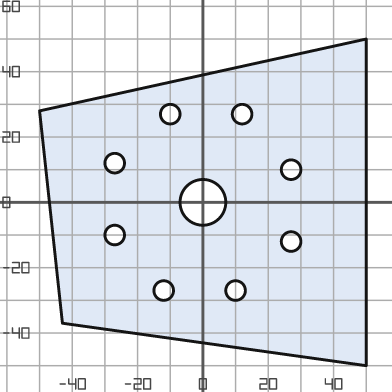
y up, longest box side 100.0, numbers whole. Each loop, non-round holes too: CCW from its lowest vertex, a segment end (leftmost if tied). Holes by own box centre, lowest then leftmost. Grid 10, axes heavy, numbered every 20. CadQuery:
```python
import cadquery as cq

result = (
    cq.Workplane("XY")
    .moveTo(50.0, -50.0)
    .lineTo(50.0, 50.0)
    .lineTo(-50.0, 28.0)
    .lineTo(-43.0, -37.0)
    .close()
    .moveTo(-12.0, -27.0)
    .circle(3.0)
    .moveTo(10.0, -27.0)
    .circle(3.0)
    .moveTo(27.0, -12.0)
    .circle(3.0)
    .moveTo(-27.0, -10.0)
    .circle(3.0)
    .moveTo(0.0, 0.0)
    .circle(7.0)
    .moveTo(27.0, 10.0)
    .circle(3.0)
    .moveTo(-27.0, 12.0)
    .circle(3.0)
    .moveTo(-10.0, 27.0)
    .circle(3.0)
    .moveTo(12.0, 27.0)
    .circle(3.0)
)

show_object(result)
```